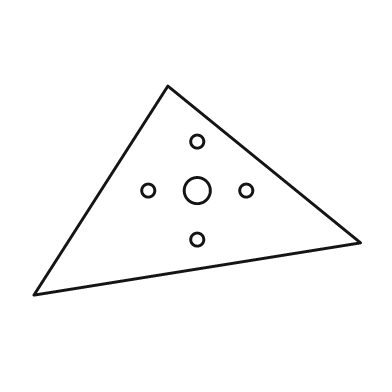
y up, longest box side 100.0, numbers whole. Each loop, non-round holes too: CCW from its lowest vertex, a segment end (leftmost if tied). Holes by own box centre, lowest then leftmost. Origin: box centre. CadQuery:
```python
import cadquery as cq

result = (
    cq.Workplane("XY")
    .moveTo(-50.0, -32.0)
    .lineTo(50.0, -16.0)
    .lineTo(-9.0, 32.0)
    .close()
    .moveTo(0.0, -15.0)
    .circle(2.0)
    .moveTo(-15.0, 0.0)
    .circle(2.0)
    .moveTo(0.0, 0.0)
    .circle(4.0)
    .moveTo(15.0, 0.0)
    .circle(2.0)
    .moveTo(0.0, 15.0)
    .circle(2.0)
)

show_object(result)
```